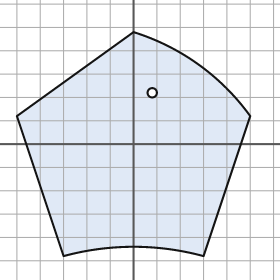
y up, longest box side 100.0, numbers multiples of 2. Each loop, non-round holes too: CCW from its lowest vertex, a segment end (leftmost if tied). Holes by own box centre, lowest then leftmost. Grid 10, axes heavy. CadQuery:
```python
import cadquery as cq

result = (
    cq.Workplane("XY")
    .moveTo(-30.0, -48.0)
    .threePointArc((0.0, -44.0), (30.0, -48.0))
    .lineTo(50.0, 12.0)
    .threePointArc((28.0, 34.0), (0.0, 48.0))
    .lineTo(-50.0, 12.0)
    .close()
    .moveTo(8.0, 22.0)
    .circle(2.0)
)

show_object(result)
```